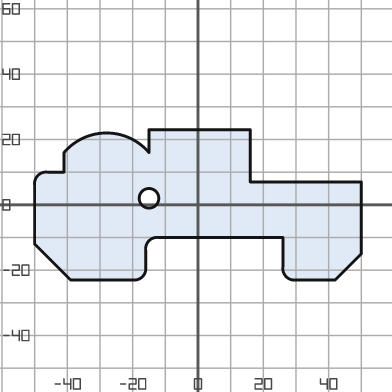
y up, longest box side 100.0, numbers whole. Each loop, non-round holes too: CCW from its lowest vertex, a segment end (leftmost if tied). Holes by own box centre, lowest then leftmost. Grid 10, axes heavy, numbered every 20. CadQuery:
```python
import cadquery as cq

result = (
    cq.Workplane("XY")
    .moveTo(-39.0, -23.0)
    .lineTo(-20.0, -23.0)
    .threePointArc((-17.0, -22.0), (-16.0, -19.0))
    .lineTo(-16.0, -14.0)
    .threePointArc((-15.0, -11.0), (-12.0, -10.0))
    .lineTo(26.0, -10.0)
    .lineTo(26.0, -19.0)
    .threePointArc((27.0, -22.0), (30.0, -23.0))
    .lineTo(42.0, -23.0)
    .lineTo(50.0, -15.0)
    .lineTo(50.0, 7.0)
    .lineTo(16.0, 7.0)
    .lineTo(16.0, 23.0)
    .lineTo(-15.0, 23.0)
    .lineTo(-15.0, 16.0)
    .threePointArc((-28.0, 22.0), (-41.0, 16.0))
    .lineTo(-41.0, 10.0)
    .lineTo(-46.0, 10.0)
    .threePointArc((-49.0, 9.0), (-50.0, 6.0))
    .lineTo(-50.0, -12.0)
    .close()
    .moveTo(-15.0, 2.0)
    .circle(3.0)
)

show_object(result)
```